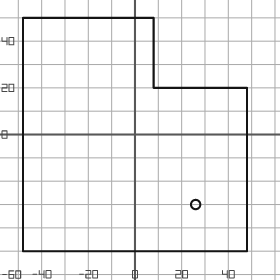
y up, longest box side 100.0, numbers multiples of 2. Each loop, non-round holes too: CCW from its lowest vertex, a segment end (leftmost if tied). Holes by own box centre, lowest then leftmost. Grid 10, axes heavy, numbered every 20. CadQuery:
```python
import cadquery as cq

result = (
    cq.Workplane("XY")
    .moveTo(-48.0, -50.0)
    .lineTo(48.0, -50.0)
    .lineTo(48.0, 20.0)
    .lineTo(8.0, 20.0)
    .lineTo(8.0, 50.0)
    .lineTo(-48.0, 50.0)
    .close()
    .moveTo(26.0, -30.0)
    .circle(2.0)
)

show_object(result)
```